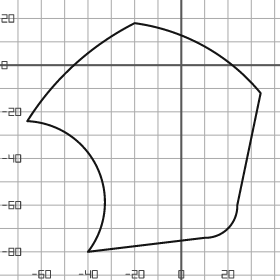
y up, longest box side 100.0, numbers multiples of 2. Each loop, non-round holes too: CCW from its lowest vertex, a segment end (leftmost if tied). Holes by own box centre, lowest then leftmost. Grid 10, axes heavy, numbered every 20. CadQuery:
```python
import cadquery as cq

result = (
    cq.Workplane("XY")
    .moveTo(-40.0, -80.0)
    .lineTo(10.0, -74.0)
    .threePointArc((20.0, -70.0), (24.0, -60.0))
    .lineTo(34.0, -12.0)
    .threePointArc((10.0, 8.0), (-20.0, 18.0))
    .threePointArc((-46.0, 0.0), (-66.0, -24.0))
    .threePointArc((-36.0, -44.0), (-40.0, -80.0))
    .close()
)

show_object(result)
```